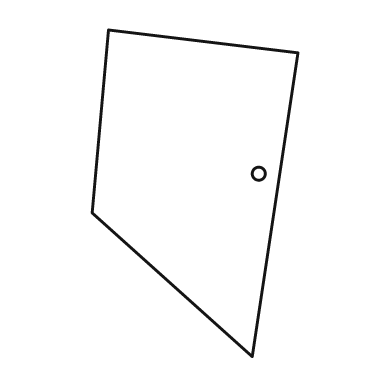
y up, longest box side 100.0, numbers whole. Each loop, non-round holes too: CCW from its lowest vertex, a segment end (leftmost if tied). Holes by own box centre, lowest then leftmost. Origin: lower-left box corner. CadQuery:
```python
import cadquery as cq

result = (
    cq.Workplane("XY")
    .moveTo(49.0, 0.0)
    .lineTo(63.0, 93.0)
    .lineTo(5.0, 100.0)
    .lineTo(0.0, 44.0)
    .close()
    .moveTo(51.0, 56.0)
    .circle(2.0)
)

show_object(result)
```